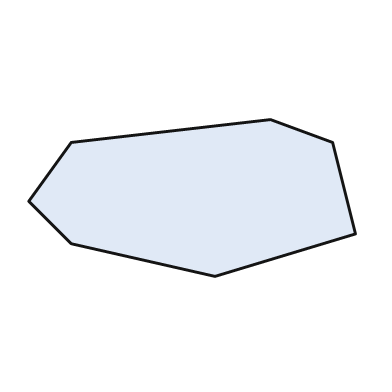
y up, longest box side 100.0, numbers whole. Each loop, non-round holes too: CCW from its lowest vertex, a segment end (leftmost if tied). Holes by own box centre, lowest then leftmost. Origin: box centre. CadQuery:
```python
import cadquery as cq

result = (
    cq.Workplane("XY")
    .moveTo(7.0, -24.0)
    .lineTo(50.0, -11.0)
    .lineTo(43.0, 17.0)
    .lineTo(24.0, 24.0)
    .lineTo(-37.0, 17.0)
    .lineTo(-50.0, -1.0)
    .lineTo(-37.0, -14.0)
    .close()
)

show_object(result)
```